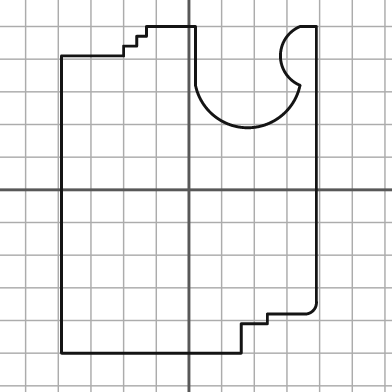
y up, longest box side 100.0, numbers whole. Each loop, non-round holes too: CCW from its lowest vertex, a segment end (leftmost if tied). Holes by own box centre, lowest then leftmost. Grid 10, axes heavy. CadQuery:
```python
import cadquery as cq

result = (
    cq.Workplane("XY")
    .moveTo(-39.0, -50.0)
    .lineTo(16.0, -50.0)
    .lineTo(16.0, -41.0)
    .lineTo(24.0, -41.0)
    .lineTo(24.0, -38.0)
    .lineTo(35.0, -38.0)
    .threePointArc((38.0, -37.0), (39.0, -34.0))
    .lineTo(39.0, 50.0)
    .lineTo(34.0, 50.0)
    .threePointArc((28.0, 41.0), (34.0, 32.0))
    .threePointArc((18.0, 19.0), (2.0, 32.0))
    .lineTo(2.0, 50.0)
    .lineTo(-13.0, 50.0)
    .lineTo(-13.0, 47.0)
    .lineTo(-16.0, 47.0)
    .lineTo(-16.0, 44.0)
    .lineTo(-20.0, 44.0)
    .lineTo(-20.0, 41.0)
    .lineTo(-39.0, 41.0)
    .close()
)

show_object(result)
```